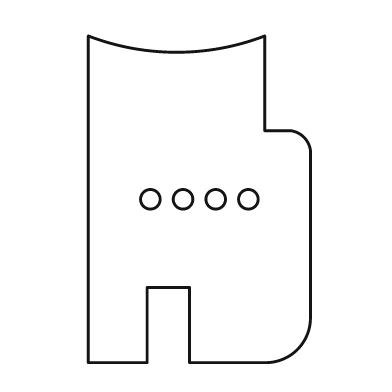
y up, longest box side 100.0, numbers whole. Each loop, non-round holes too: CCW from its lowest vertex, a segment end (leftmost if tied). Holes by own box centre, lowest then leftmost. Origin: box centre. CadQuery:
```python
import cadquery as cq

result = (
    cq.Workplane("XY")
    .moveTo(-34.0, -50.0)
    .lineTo(-16.0, -50.0)
    .lineTo(-16.0, -27.0)
    .lineTo(-3.0, -27.0)
    .lineTo(-3.0, -50.0)
    .lineTo(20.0, -50.0)
    .threePointArc((30.0, -46.0), (34.0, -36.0))
    .lineTo(34.0, 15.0)
    .threePointArc((32.0, 19.0), (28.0, 21.0))
    .lineTo(20.0, 21.0)
    .lineTo(20.0, 50.0)
    .threePointArc((-7.0, 45.0), (-34.0, 50.0))
    .close()
    .moveTo(-15.0, 0.0)
    .circle(3.0)
    .moveTo(-5.0, 0.0)
    .circle(3.0)
    .moveTo(5.0, 0.0)
    .circle(3.0)
    .moveTo(15.0, 0.0)
    .circle(3.0)
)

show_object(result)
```